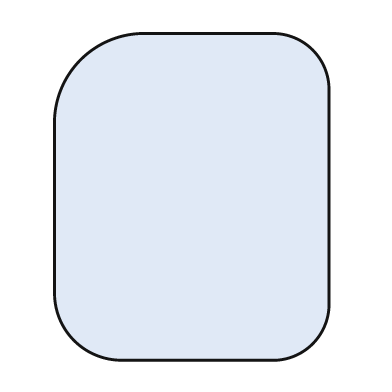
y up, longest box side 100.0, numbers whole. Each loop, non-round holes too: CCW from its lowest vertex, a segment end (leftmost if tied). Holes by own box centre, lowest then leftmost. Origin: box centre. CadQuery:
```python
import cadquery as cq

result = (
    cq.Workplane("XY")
    .moveTo(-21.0, -50.0)
    .lineTo(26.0, -50.0)
    .threePointArc((37.0, -45.0), (42.0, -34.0))
    .lineTo(42.0, 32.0)
    .threePointArc((37.0, 45.0), (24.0, 50.0))
    .lineTo(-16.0, 50.0)
    .threePointArc((-34.0, 42.0), (-42.0, 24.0))
    .lineTo(-42.0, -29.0)
    .threePointArc((-36.0, -44.0), (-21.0, -50.0))
    .close()
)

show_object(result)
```